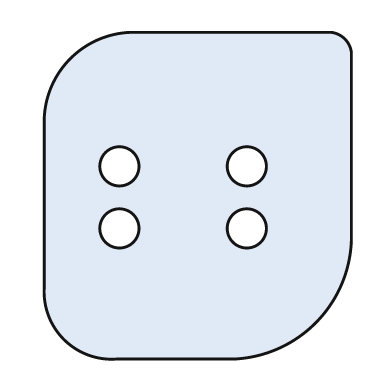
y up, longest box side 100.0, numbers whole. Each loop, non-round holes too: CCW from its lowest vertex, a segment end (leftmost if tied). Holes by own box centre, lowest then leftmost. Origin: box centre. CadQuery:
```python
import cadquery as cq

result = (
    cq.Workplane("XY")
    .moveTo(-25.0, -50.0)
    .lineTo(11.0, -50.0)
    .threePointArc((36.0, -39.0), (47.0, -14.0))
    .lineTo(47.0, 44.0)
    .threePointArc((45.0, 48.0), (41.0, 50.0))
    .lineTo(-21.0, 50.0)
    .threePointArc((-39.0, 42.0), (-47.0, 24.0))
    .lineTo(-47.0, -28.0)
    .threePointArc((-41.0, -44.0), (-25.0, -50.0))
    .close()
    .moveTo(-24.0, -10.0)
    .circle(6.0)
    .moveTo(15.0, -10.0)
    .circle(6.0)
    .moveTo(-24.0, 9.0)
    .circle(6.0)
    .moveTo(15.0, 9.0)
    .circle(6.0)
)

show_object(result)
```